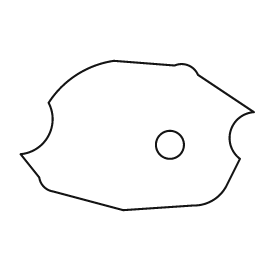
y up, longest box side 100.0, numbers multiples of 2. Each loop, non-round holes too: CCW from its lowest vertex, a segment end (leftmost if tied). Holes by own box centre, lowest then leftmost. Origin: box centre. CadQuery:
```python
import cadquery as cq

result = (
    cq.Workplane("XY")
    .moveTo(-6.0, -32.0)
    .lineTo(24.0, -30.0)
    .threePointArc((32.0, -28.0), (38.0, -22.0))
    .lineTo(44.0, -10.0)
    .threePointArc((40.0, 2.0), (50.0, 10.0))
    .lineTo(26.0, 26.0)
    .threePointArc((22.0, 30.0), (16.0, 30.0))
    .lineTo(-10.0, 32.0)
    .threePointArc((-26.0, 26.0), (-38.0, 14.0))
    .threePointArc((-38.0, 0.0), (-50.0, -8.0))
    .lineTo(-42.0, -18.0)
    .threePointArc((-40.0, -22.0), (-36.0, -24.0))
    .close()
    .moveTo(14.0, -4.0)
    .circle(6.0)
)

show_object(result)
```